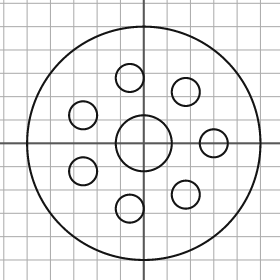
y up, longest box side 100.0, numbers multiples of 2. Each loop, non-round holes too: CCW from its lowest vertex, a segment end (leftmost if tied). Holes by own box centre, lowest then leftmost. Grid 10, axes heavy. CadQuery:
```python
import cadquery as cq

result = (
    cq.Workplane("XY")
    .moveTo(0.0, 0.0)
    .circle(50.0)
    .moveTo(-6.0, -28.0)
    .circle(6.0)
    .moveTo(18.0, -22.0)
    .circle(6.0)
    .moveTo(-26.0, -12.0)
    .circle(6.0)
    .moveTo(0.0, 0.0)
    .circle(12.0)
    .moveTo(30.0, 0.0)
    .circle(6.0)
    .moveTo(-26.0, 12.0)
    .circle(6.0)
    .moveTo(18.0, 22.0)
    .circle(6.0)
    .moveTo(-6.0, 28.0)
    .circle(6.0)
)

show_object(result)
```